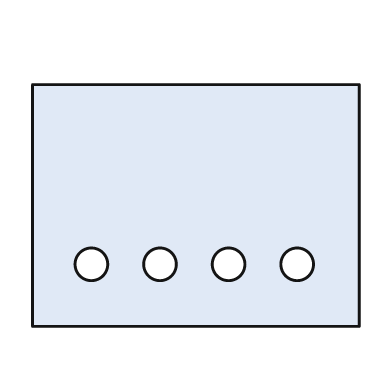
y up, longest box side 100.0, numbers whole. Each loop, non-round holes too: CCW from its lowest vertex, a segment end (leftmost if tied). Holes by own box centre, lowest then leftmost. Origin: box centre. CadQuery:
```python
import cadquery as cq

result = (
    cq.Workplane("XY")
    .moveTo(-50.0, -37.0)
    .lineTo(50.0, -37.0)
    .lineTo(50.0, 37.0)
    .lineTo(-50.0, 37.0)
    .close()
    .moveTo(-32.0, -18.0)
    .circle(5.0)
    .moveTo(-11.0, -18.0)
    .circle(5.0)
    .moveTo(10.0, -18.0)
    .circle(5.0)
    .moveTo(31.0, -18.0)
    .circle(5.0)
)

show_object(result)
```